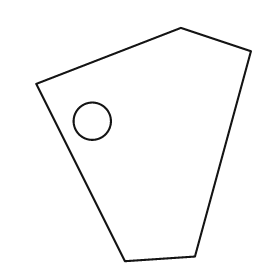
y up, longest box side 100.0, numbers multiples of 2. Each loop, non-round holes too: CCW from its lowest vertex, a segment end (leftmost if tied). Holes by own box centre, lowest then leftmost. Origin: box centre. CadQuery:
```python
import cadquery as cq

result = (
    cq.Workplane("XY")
    .moveTo(-8.0, -50.0)
    .lineTo(22.0, -48.0)
    .lineTo(46.0, 40.0)
    .lineTo(16.0, 50.0)
    .lineTo(-46.0, 26.0)
    .close()
    .moveTo(-22.0, 10.0)
    .circle(8.0)
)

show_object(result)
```